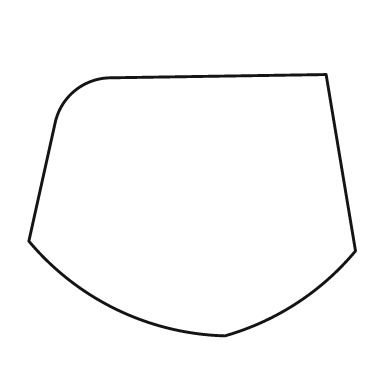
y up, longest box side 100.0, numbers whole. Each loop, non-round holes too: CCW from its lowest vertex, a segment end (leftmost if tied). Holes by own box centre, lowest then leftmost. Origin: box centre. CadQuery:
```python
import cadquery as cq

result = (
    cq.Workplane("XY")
    .moveTo(10.0, -40.0)
    .threePointArc((32.0, -30.0), (50.0, -14.0))
    .lineTo(41.0, 40.0)
    .lineTo(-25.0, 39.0)
    .threePointArc((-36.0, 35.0), (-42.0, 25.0))
    .lineTo(-50.0, -11.0)
    .threePointArc((-23.0, -32.0), (10.0, -40.0))
    .close()
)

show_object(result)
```